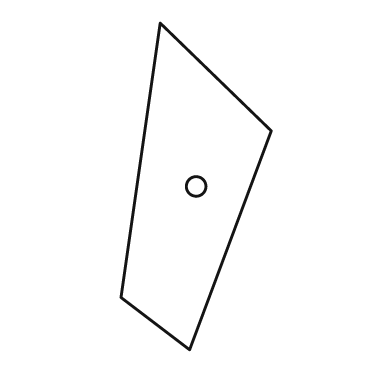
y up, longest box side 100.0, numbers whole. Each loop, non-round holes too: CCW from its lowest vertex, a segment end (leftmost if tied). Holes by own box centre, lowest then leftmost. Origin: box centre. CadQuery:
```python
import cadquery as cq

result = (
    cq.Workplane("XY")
    .moveTo(-2.0, -50.0)
    .lineTo(23.0, 17.0)
    .lineTo(-11.0, 50.0)
    .lineTo(-23.0, -34.0)
    .close()
    .moveTo(0.0, 0.0)
    .circle(3.0)
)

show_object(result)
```